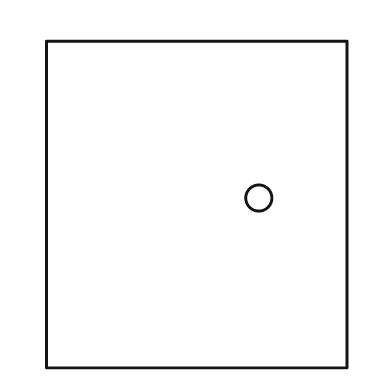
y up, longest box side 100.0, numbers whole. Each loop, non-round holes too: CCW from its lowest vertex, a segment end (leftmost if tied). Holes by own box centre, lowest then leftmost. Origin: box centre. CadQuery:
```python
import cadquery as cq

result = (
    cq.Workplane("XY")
    .moveTo(-46.0, -50.0)
    .lineTo(46.0, -50.0)
    .lineTo(46.0, 50.0)
    .lineTo(-46.0, 50.0)
    .close()
    .moveTo(19.0, 2.0)
    .circle(4.0)
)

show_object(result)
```